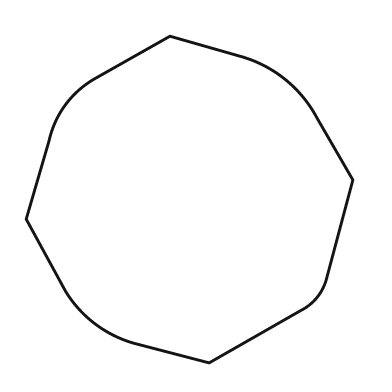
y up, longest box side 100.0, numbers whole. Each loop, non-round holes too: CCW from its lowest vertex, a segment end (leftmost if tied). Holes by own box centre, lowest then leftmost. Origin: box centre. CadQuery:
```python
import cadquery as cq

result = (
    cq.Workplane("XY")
    .moveTo(6.0, -50.0)
    .lineTo(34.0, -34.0)
    .threePointArc((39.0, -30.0), (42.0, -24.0))
    .lineTo(50.0, 6.0)
    .lineTo(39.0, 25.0)
    .threePointArc((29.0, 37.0), (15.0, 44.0))
    .lineTo(-6.0, 50.0)
    .lineTo(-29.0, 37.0)
    .threePointArc((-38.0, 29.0), (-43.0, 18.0))
    .lineTo(-50.0, -6.0)
    .lineTo(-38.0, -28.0)
    .threePointArc((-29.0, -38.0), (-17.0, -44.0))
    .close()
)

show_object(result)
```